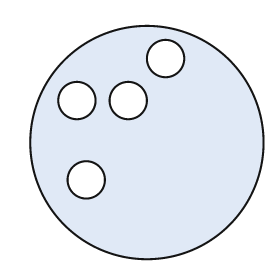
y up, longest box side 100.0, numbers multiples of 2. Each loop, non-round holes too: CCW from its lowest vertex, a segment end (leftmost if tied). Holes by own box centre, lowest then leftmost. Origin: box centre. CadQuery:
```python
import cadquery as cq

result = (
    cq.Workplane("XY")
    .moveTo(0.0, 0.0)
    .circle(50.0)
    .moveTo(-26.0, -16.0)
    .circle(8.0)
    .moveTo(-30.0, 18.0)
    .circle(8.0)
    .moveTo(-8.0, 18.0)
    .circle(8.0)
    .moveTo(8.0, 36.0)
    .circle(8.0)
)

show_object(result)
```